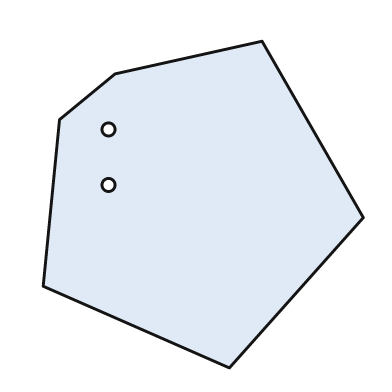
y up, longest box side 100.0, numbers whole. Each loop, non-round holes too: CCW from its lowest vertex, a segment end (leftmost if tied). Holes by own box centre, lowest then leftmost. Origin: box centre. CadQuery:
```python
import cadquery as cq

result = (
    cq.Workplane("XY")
    .moveTo(8.0, -50.0)
    .lineTo(49.0, -4.0)
    .lineTo(18.0, 50.0)
    .lineTo(-27.0, 40.0)
    .lineTo(-44.0, 26.0)
    .lineTo(-49.0, -25.0)
    .close()
    .moveTo(-29.0, 6.0)
    .circle(2.0)
    .moveTo(-29.0, 23.0)
    .circle(2.0)
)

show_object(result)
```